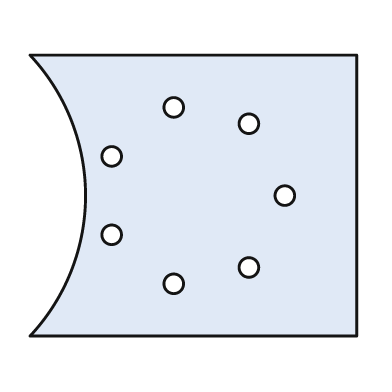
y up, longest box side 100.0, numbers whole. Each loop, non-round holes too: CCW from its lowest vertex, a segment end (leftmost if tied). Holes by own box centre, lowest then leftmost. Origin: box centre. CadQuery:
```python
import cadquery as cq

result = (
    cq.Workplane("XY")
    .moveTo(-50.0, -43.0)
    .lineTo(50.0, -43.0)
    .lineTo(50.0, 43.0)
    .lineTo(-50.0, 43.0)
    .threePointArc((-33.0, 0.0), (-50.0, -43.0))
    .close()
    .moveTo(-6.0, -27.0)
    .circle(3.0)
    .moveTo(17.0, -22.0)
    .circle(3.0)
    .moveTo(-25.0, -12.0)
    .circle(3.0)
    .moveTo(28.0, 0.0)
    .circle(3.0)
    .moveTo(-25.0, 12.0)
    .circle(3.0)
    .moveTo(17.0, 22.0)
    .circle(3.0)
    .moveTo(-6.0, 27.0)
    .circle(3.0)
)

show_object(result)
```